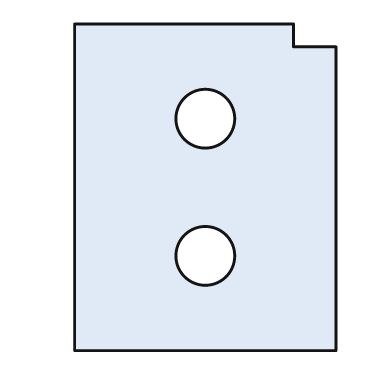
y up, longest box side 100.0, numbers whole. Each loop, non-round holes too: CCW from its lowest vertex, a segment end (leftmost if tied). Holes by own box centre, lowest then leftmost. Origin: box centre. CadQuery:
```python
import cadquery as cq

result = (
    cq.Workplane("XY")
    .moveTo(-40.0, -50.0)
    .lineTo(40.0, -50.0)
    .lineTo(40.0, 43.0)
    .lineTo(27.0, 43.0)
    .lineTo(27.0, 50.0)
    .lineTo(-40.0, 50.0)
    .close()
    .moveTo(0.0, -21.0)
    .circle(9.0)
    .moveTo(0.0, 21.0)
    .circle(9.0)
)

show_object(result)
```